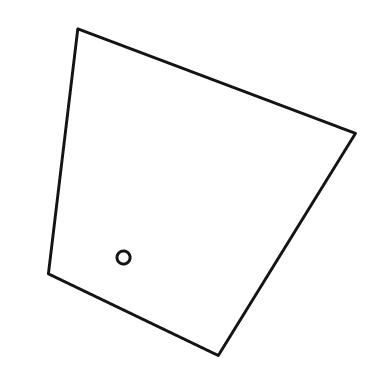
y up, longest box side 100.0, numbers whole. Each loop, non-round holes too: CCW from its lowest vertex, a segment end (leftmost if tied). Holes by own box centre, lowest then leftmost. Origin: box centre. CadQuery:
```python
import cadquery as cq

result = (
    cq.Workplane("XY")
    .moveTo(5.0, -50.0)
    .lineTo(47.0, 18.0)
    .lineTo(-38.0, 50.0)
    .lineTo(-47.0, -25.0)
    .close()
    .moveTo(-24.0, -20.0)
    .circle(2.0)
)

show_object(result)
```